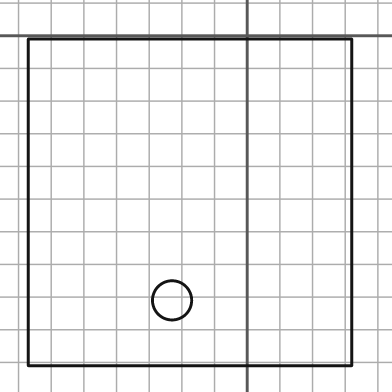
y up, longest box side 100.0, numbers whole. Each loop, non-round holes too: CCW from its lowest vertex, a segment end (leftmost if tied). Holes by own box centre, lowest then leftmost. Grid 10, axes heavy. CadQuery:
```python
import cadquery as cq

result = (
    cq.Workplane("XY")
    .moveTo(-67.0, -101.0)
    .lineTo(32.0, -101.0)
    .lineTo(32.0, -1.0)
    .lineTo(-67.0, -1.0)
    .close()
    .moveTo(-23.0, -81.0)
    .circle(6.0)
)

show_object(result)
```